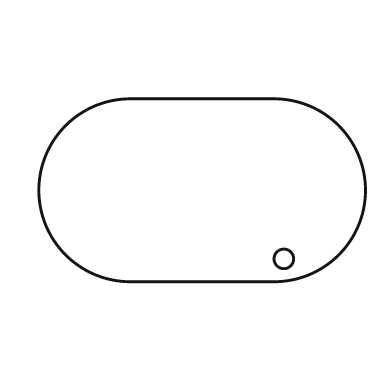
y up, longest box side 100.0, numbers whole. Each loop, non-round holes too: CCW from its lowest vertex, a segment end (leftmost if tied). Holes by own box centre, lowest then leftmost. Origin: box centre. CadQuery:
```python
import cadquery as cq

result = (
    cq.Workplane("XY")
    .moveTo(-22.0, -28.0)
    .lineTo(22.0, -28.0)
    .threePointArc((50.0, 0.0), (22.0, 28.0))
    .lineTo(-22.0, 28.0)
    .threePointArc((-50.0, 0.0), (-22.0, -28.0))
    .close()
    .moveTo(25.0, -21.0)
    .circle(3.0)
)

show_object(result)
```